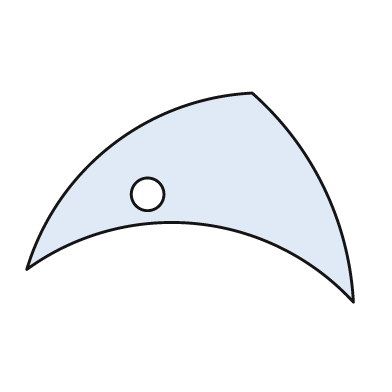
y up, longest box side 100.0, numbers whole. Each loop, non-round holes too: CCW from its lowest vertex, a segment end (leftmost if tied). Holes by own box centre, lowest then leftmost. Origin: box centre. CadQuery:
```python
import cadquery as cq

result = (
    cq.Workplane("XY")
    .moveTo(50.0, -32.0)
    .threePointArc((41.0, 3.0), (19.0, 32.0))
    .threePointArc((-24.0, 16.0), (-50.0, -22.0))
    .threePointArc((2.0, -8.0), (50.0, -32.0))
    .close()
    .moveTo(-13.0, 1.0)
    .circle(5.0)
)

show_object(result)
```